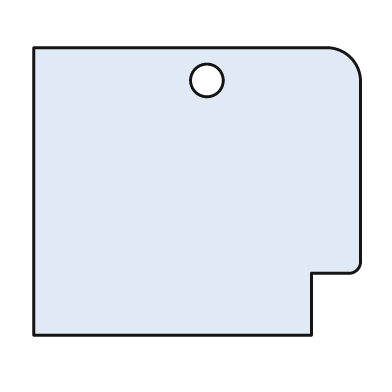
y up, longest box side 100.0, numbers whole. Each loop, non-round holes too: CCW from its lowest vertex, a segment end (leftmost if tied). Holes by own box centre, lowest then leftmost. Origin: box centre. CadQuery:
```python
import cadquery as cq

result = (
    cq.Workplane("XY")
    .moveTo(-50.0, -44.0)
    .lineTo(35.0, -44.0)
    .lineTo(35.0, -25.0)
    .lineTo(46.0, -25.0)
    .threePointArc((49.0, -24.0), (50.0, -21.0))
    .lineTo(50.0, 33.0)
    .threePointArc((47.0, 41.0), (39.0, 44.0))
    .lineTo(-50.0, 44.0)
    .close()
    .moveTo(3.0, 34.0)
    .circle(5.0)
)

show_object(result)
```